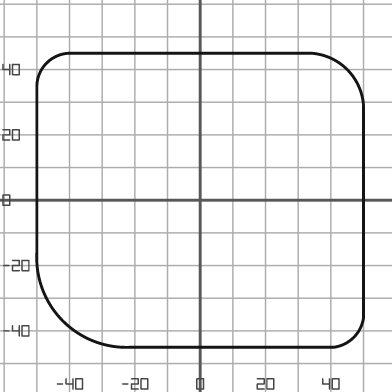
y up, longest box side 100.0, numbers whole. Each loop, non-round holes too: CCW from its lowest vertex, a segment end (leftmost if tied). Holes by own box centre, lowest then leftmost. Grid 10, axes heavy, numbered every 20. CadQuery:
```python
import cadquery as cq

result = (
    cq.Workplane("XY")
    .moveTo(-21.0, -45.0)
    .lineTo(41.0, -45.0)
    .threePointArc((47.0, -42.0), (50.0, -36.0))
    .lineTo(50.0, 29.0)
    .threePointArc((45.0, 40.0), (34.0, 45.0))
    .lineTo(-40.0, 45.0)
    .threePointArc((-47.0, 42.0), (-50.0, 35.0))
    .lineTo(-50.0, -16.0)
    .threePointArc((-42.0, -37.0), (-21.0, -45.0))
    .close()
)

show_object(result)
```